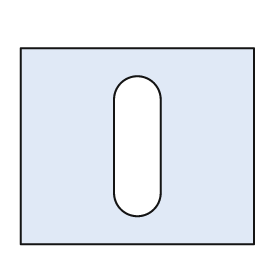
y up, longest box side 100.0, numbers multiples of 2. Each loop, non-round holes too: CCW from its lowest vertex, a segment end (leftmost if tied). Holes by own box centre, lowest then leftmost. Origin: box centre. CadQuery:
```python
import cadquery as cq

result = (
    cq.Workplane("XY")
    .moveTo(-50.0, -42.0)
    .lineTo(50.0, -42.0)
    .lineTo(50.0, 42.0)
    .lineTo(-50.0, 42.0)
    .close()
    .moveTo(-10.0, -20.0)
    .threePointArc((0.0, -30.0), (10.0, -20.0))
    .lineTo(10.0, 20.0)
    .threePointArc((0.0, 30.0), (-10.0, 20.0))
    .close()
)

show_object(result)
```